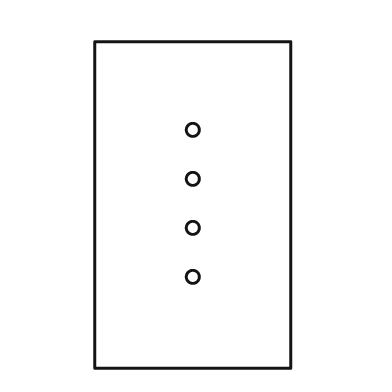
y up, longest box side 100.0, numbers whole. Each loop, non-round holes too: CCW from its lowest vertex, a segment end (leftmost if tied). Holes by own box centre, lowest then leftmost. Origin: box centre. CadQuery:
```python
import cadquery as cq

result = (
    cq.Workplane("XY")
    .moveTo(-30.0, -50.0)
    .lineTo(30.0, -50.0)
    .lineTo(30.0, 50.0)
    .lineTo(-30.0, 50.0)
    .close()
    .moveTo(0.0, -22.0)
    .circle(2.0)
    .moveTo(0.0, -7.0)
    .circle(2.0)
    .moveTo(0.0, 8.0)
    .circle(2.0)
    .moveTo(0.0, 23.0)
    .circle(2.0)
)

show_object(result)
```